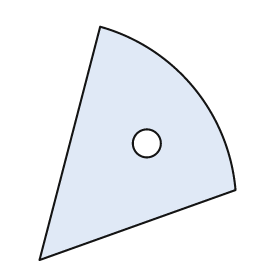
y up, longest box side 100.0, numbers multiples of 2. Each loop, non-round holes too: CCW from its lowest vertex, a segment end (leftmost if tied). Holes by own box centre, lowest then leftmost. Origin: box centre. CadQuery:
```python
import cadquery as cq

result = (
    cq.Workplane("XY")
    .moveTo(-42.0, -50.0)
    .lineTo(42.0, -20.0)
    .threePointArc((24.0, 24.0), (-16.0, 50.0))
    .close()
    .moveTo(4.0, 0.0)
    .circle(6.0)
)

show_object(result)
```